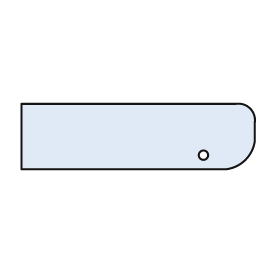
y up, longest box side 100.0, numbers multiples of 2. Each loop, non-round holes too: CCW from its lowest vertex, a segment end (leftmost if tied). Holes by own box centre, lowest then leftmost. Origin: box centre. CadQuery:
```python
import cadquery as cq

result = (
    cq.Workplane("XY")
    .moveTo(-50.0, -14.0)
    .lineTo(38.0, -14.0)
    .threePointArc((46.0, -10.0), (50.0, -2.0))
    .lineTo(50.0, 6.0)
    .threePointArc((48.0, 12.0), (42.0, 14.0))
    .lineTo(-50.0, 14.0)
    .close()
    .moveTo(28.0, -8.0)
    .circle(2.0)
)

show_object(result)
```